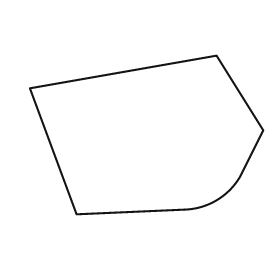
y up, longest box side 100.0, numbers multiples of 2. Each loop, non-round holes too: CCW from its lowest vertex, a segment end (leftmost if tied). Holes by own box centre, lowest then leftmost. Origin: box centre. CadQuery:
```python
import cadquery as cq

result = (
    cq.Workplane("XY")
    .moveTo(-30.0, -34.0)
    .lineTo(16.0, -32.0)
    .threePointArc((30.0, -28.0), (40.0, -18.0))
    .lineTo(50.0, 2.0)
    .lineTo(30.0, 34.0)
    .lineTo(-50.0, 20.0)
    .close()
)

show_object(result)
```